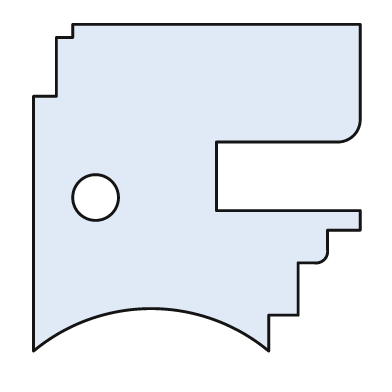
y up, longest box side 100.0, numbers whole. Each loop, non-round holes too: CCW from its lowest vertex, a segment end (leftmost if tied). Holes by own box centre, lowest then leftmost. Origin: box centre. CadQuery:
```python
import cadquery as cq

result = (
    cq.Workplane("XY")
    .moveTo(-50.0, -50.0)
    .threePointArc((-14.0, -37.0), (22.0, -50.0))
    .lineTo(22.0, -39.0)
    .lineTo(31.0, -39.0)
    .lineTo(31.0, -23.0)
    .lineTo(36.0, -23.0)
    .threePointArc((39.0, -22.0), (40.0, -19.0))
    .lineTo(40.0, -13.0)
    .lineTo(50.0, -13.0)
    .lineTo(50.0, -7.0)
    .lineTo(6.0, -7.0)
    .lineTo(6.0, 14.0)
    .lineTo(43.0, 14.0)
    .threePointArc((48.0, 16.0), (50.0, 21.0))
    .lineTo(50.0, 50.0)
    .lineTo(-38.0, 50.0)
    .lineTo(-38.0, 46.0)
    .lineTo(-43.0, 46.0)
    .lineTo(-43.0, 28.0)
    .lineTo(-50.0, 28.0)
    .close()
    .moveTo(-31.0, -3.0)
    .circle(7.0)
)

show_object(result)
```